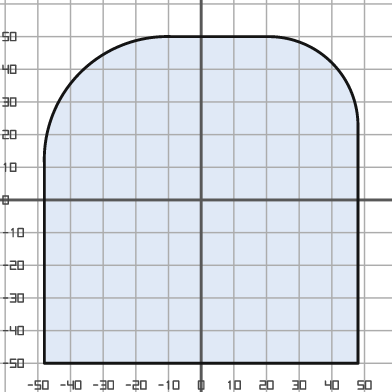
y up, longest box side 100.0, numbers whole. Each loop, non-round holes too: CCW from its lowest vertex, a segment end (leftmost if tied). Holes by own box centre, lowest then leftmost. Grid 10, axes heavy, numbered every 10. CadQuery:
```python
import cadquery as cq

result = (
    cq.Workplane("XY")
    .moveTo(-48.0, -50.0)
    .lineTo(48.0, -50.0)
    .lineTo(48.0, 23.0)
    .threePointArc((40.0, 42.0), (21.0, 50.0))
    .lineTo(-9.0, 50.0)
    .threePointArc((-37.0, 39.0), (-48.0, 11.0))
    .close()
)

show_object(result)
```